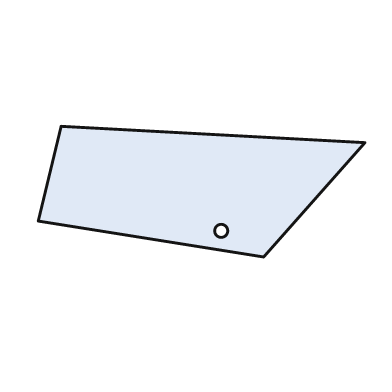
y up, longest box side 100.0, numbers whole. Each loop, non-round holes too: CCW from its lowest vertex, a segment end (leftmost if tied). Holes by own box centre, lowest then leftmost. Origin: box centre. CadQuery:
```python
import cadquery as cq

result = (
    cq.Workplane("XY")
    .moveTo(19.0, -20.0)
    .lineTo(50.0, 15.0)
    .lineTo(-43.0, 20.0)
    .lineTo(-50.0, -9.0)
    .close()
    .moveTo(6.0, -12.0)
    .circle(2.0)
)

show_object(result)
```